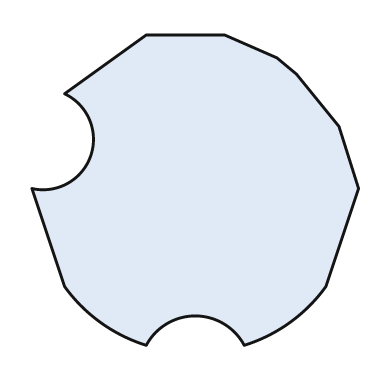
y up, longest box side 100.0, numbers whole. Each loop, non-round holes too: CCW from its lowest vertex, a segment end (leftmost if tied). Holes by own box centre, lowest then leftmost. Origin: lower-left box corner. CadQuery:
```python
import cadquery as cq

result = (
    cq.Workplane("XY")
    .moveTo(35.0, 0.0)
    .threePointArc((50.0, 9.0), (65.0, 0.0))
    .threePointArc((79.0, 7.0), (90.0, 18.0))
    .lineTo(100.0, 48.0)
    .lineTo(94.0, 67.0)
    .lineTo(81.0, 83.0)
    .lineTo(75.0, 88.0)
    .lineTo(59.0, 95.0)
    .lineTo(35.0, 95.0)
    .lineTo(10.0, 77.0)
    .threePointArc((18.0, 58.0), (0.0, 48.0))
    .lineTo(10.0, 18.0)
    .threePointArc((21.0, 7.0), (35.0, 0.0))
    .close()
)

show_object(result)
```